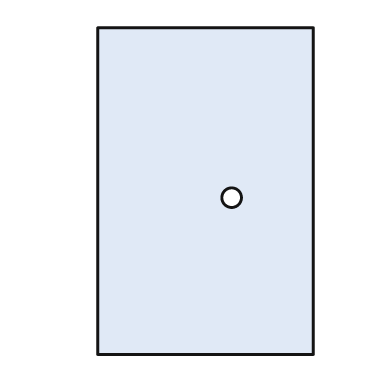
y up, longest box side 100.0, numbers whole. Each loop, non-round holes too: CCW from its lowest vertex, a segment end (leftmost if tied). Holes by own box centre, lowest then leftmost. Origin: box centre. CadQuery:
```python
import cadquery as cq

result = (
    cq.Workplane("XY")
    .moveTo(-33.0, -50.0)
    .lineTo(33.0, -50.0)
    .lineTo(33.0, 50.0)
    .lineTo(-33.0, 50.0)
    .close()
    .moveTo(8.0, -2.0)
    .circle(3.0)
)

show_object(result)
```